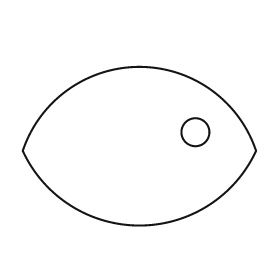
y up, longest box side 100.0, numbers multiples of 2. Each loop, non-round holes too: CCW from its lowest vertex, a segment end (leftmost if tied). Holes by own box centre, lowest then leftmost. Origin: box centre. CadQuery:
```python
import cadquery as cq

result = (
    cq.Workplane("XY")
    .moveTo(-50.0, -2.0)
    .threePointArc((0.0, -34.0), (50.0, -2.0))
    .threePointArc((0.0, 34.0), (-50.0, -2.0))
    .close()
    .moveTo(24.0, 6.0)
    .circle(6.0)
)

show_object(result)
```